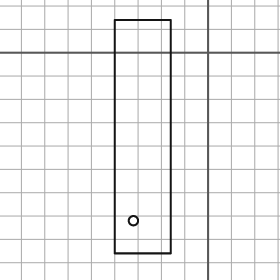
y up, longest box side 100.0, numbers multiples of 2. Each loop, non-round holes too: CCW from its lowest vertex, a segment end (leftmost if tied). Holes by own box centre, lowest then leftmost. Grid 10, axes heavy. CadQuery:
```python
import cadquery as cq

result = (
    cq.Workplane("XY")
    .moveTo(-40.0, -86.0)
    .lineTo(-16.0, -86.0)
    .lineTo(-16.0, 14.0)
    .lineTo(-40.0, 14.0)
    .close()
    .moveTo(-32.0, -72.0)
    .circle(2.0)
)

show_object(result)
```